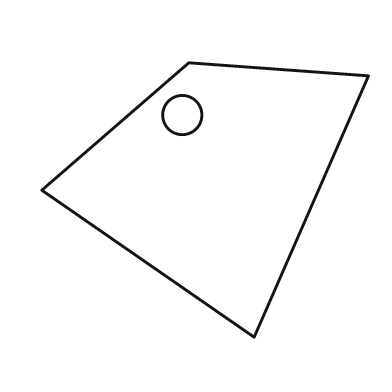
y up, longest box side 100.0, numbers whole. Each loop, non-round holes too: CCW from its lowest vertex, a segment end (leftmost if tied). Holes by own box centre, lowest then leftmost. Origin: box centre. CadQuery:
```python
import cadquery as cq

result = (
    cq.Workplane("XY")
    .moveTo(15.0, -42.0)
    .lineTo(50.0, 38.0)
    .lineTo(-5.0, 42.0)
    .lineTo(-50.0, 3.0)
    .close()
    .moveTo(-7.0, 26.0)
    .circle(6.0)
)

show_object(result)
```